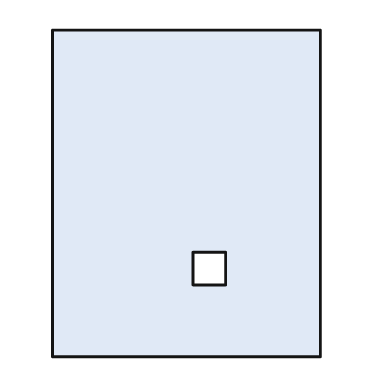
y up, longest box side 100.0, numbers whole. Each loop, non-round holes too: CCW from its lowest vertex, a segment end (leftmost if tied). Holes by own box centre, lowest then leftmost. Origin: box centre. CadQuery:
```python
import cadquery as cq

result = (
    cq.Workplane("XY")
    .moveTo(-41.0, -50.0)
    .lineTo(41.0, -50.0)
    .lineTo(41.0, 50.0)
    .lineTo(-41.0, 50.0)
    .close()
    .moveTo(2.0, -28.0)
    .lineTo(12.0, -28.0)
    .lineTo(12.0, -18.0)
    .lineTo(2.0, -18.0)
    .close()
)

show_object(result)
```